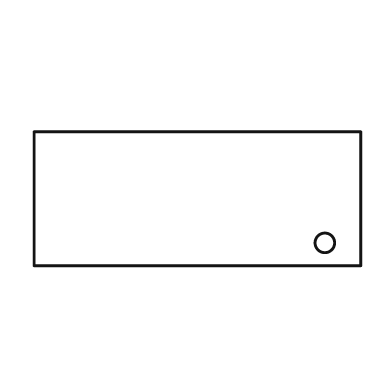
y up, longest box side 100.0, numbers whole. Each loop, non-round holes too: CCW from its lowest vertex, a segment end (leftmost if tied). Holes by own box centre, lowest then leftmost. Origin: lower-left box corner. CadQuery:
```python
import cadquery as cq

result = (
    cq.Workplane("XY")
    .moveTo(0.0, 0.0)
    .lineTo(100.0, 0.0)
    .lineTo(100.0, 41.0)
    .lineTo(0.0, 41.0)
    .close()
    .moveTo(89.0, 7.0)
    .circle(3.0)
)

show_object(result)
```